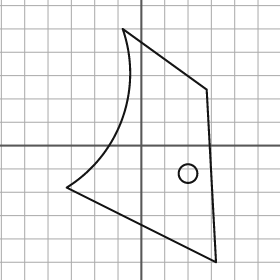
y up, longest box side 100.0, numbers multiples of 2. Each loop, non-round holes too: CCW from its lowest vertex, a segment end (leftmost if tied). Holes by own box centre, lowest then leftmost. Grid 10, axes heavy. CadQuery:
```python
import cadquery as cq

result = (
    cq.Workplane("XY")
    .moveTo(32.0, -50.0)
    .lineTo(28.0, 24.0)
    .lineTo(-8.0, 50.0)
    .threePointArc((-8.0, 12.0), (-32.0, -18.0))
    .close()
    .moveTo(20.0, -12.0)
    .circle(4.0)
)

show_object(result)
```